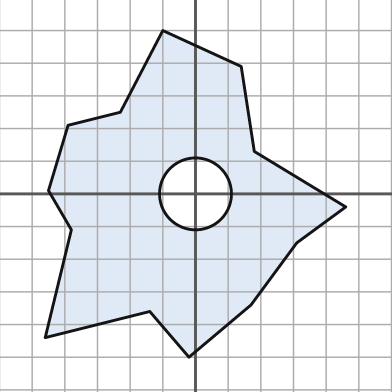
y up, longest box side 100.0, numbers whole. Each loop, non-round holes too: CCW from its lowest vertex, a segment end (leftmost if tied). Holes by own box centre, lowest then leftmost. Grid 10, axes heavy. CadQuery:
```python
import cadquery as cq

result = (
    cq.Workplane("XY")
    .moveTo(-2.0, -50.0)
    .lineTo(17.0, -34.0)
    .lineTo(31.0, -15.0)
    .lineTo(46.0, -4.0)
    .lineTo(18.0, 13.0)
    .lineTo(14.0, 39.0)
    .lineTo(-10.0, 50.0)
    .lineTo(-23.0, 25.0)
    .lineTo(-39.0, 21.0)
    .lineTo(-45.0, 1.0)
    .lineTo(-38.0, -11.0)
    .lineTo(-46.0, -44.0)
    .lineTo(-14.0, -36.0)
    .close()
    .moveTo(0.0, 0.0)
    .circle(11.0)
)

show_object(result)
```